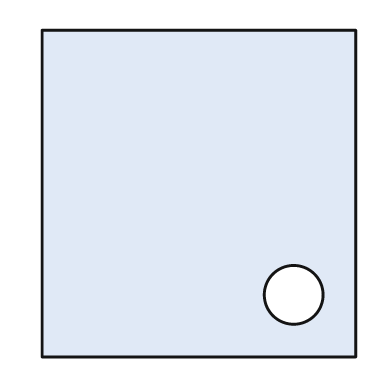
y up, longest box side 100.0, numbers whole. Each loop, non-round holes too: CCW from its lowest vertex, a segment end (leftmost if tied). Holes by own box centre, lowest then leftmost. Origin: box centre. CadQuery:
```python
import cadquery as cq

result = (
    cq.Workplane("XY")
    .moveTo(-48.0, -50.0)
    .lineTo(48.0, -50.0)
    .lineTo(48.0, 50.0)
    .lineTo(-48.0, 50.0)
    .close()
    .moveTo(29.0, -31.0)
    .circle(9.0)
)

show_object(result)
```